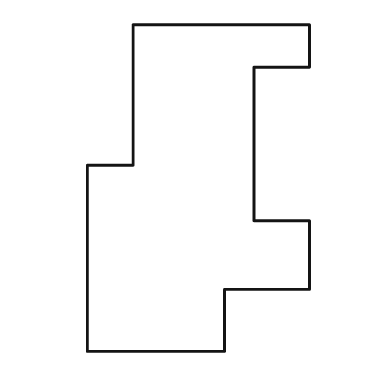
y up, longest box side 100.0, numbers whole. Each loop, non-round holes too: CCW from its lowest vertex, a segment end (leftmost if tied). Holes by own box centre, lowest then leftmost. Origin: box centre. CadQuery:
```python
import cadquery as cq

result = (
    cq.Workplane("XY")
    .moveTo(-34.0, -50.0)
    .lineTo(8.0, -50.0)
    .lineTo(8.0, -31.0)
    .lineTo(34.0, -31.0)
    .lineTo(34.0, -10.0)
    .lineTo(17.0, -10.0)
    .lineTo(17.0, 37.0)
    .lineTo(34.0, 37.0)
    .lineTo(34.0, 50.0)
    .lineTo(-20.0, 50.0)
    .lineTo(-20.0, 7.0)
    .lineTo(-34.0, 7.0)
    .close()
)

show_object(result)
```